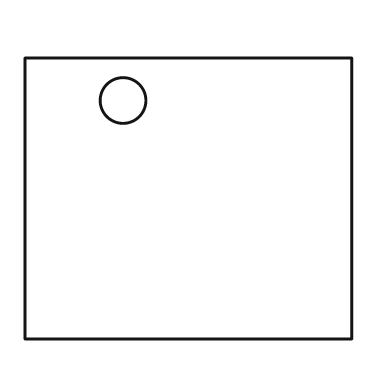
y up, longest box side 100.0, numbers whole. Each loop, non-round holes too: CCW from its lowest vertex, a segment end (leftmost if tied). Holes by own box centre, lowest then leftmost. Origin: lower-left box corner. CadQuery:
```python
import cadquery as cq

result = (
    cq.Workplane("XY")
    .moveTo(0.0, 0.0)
    .lineTo(100.0, 0.0)
    .lineTo(100.0, 86.0)
    .lineTo(0.0, 86.0)
    .close()
    .moveTo(30.0, 73.0)
    .circle(7.0)
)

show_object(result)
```